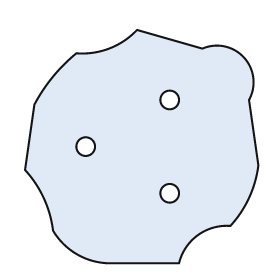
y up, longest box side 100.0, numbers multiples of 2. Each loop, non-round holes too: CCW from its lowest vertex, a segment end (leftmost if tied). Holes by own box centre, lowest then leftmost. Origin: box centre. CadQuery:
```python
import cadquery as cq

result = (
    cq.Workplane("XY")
    .moveTo(-14.0, -50.0)
    .lineTo(16.0, -50.0)
    .threePointArc((24.0, -38.0), (38.0, -34.0))
    .threePointArc((46.0, -22.0), (50.0, -8.0))
    .lineTo(46.0, 20.0)
    .threePointArc((44.0, 38.0), (26.0, 42.0))
    .lineTo(-2.0, 50.0)
    .threePointArc((-14.0, 42.0), (-28.0, 40.0))
    .threePointArc((-38.0, 30.0), (-46.0, 18.0))
    .lineTo(-50.0, -10.0)
    .threePointArc((-42.0, -22.0), (-38.0, -36.0))
    .threePointArc((-28.0, -46.0), (-14.0, -50.0))
    .close()
    .moveTo(12.0, -20.0)
    .circle(4.0)
    .moveTo(-24.0, 0.0)
    .circle(4.0)
    .moveTo(12.0, 20.0)
    .circle(4.0)
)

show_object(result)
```